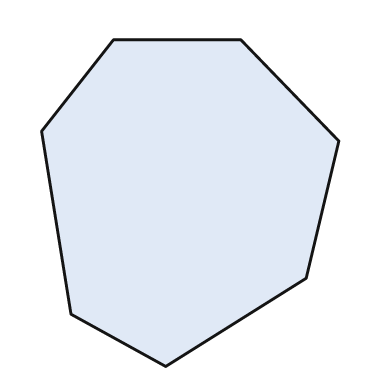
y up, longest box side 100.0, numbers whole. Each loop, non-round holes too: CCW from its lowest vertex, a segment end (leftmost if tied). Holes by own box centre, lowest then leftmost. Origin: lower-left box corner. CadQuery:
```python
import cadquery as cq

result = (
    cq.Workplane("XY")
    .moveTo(38.0, 0.0)
    .lineTo(81.0, 27.0)
    .lineTo(91.0, 69.0)
    .lineTo(61.0, 100.0)
    .lineTo(22.0, 100.0)
    .lineTo(0.0, 72.0)
    .lineTo(9.0, 16.0)
    .close()
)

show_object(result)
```